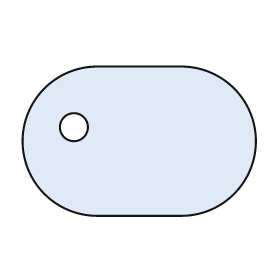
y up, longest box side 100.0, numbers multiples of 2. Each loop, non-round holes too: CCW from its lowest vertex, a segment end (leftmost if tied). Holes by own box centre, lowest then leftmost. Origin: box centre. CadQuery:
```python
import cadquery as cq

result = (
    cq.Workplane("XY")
    .moveTo(-18.0, -32.0)
    .lineTo(18.0, -32.0)
    .threePointArc((50.0, 0.0), (18.0, 32.0))
    .lineTo(-18.0, 32.0)
    .threePointArc((-50.0, 0.0), (-18.0, -32.0))
    .close()
    .moveTo(-28.0, 6.0)
    .circle(6.0)
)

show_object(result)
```